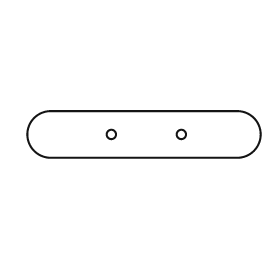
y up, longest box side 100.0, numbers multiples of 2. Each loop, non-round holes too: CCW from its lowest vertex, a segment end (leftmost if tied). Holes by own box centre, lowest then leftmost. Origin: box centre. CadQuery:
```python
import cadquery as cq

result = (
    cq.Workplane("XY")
    .moveTo(-40.0, -10.0)
    .lineTo(40.0, -10.0)
    .threePointArc((50.0, 0.0), (40.0, 10.0))
    .lineTo(-40.0, 10.0)
    .threePointArc((-50.0, 0.0), (-40.0, -10.0))
    .close()
    .moveTo(-14.0, 0.0)
    .circle(2.0)
    .moveTo(16.0, 0.0)
    .circle(2.0)
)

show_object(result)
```